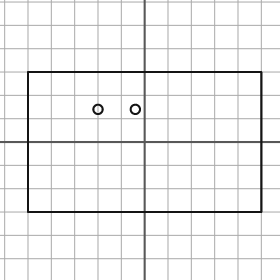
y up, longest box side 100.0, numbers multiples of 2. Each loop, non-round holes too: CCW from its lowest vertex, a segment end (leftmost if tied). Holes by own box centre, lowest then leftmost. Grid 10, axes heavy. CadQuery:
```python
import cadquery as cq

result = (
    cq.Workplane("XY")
    .moveTo(-50.0, -30.0)
    .lineTo(50.0, -30.0)
    .lineTo(50.0, 30.0)
    .lineTo(-50.0, 30.0)
    .close()
    .moveTo(-20.0, 14.0)
    .circle(2.0)
    .moveTo(-4.0, 14.0)
    .circle(2.0)
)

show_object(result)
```